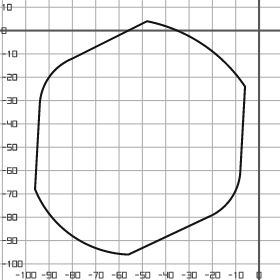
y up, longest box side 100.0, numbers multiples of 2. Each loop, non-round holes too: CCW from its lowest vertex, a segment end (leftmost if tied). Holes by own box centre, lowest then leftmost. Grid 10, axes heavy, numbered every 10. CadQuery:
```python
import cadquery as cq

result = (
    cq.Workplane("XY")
    .moveTo(-56.0, -96.0)
    .lineTo(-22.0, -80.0)
    .threePointArc((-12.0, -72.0), (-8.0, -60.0))
    .lineTo(-6.0, -24.0)
    .threePointArc((-24.0, -6.0), (-48.0, 4.0))
    .lineTo(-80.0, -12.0)
    .threePointArc((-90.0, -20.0), (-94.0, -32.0))
    .lineTo(-96.0, -68.0)
    .threePointArc((-80.0, -88.0), (-56.0, -96.0))
    .close()
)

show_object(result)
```